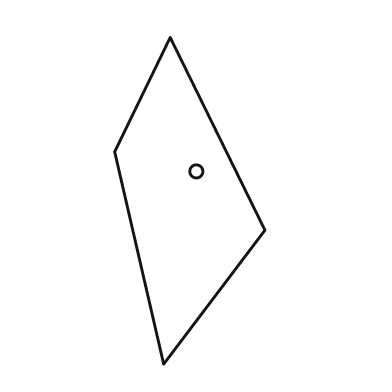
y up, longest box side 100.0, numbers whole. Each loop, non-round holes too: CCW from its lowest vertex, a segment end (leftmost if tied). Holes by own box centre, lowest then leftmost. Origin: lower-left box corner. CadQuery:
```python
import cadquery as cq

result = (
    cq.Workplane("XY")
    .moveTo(15.0, 0.0)
    .lineTo(46.0, 41.0)
    .lineTo(17.0, 100.0)
    .lineTo(0.0, 65.0)
    .close()
    .moveTo(25.0, 59.0)
    .circle(2.0)
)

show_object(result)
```